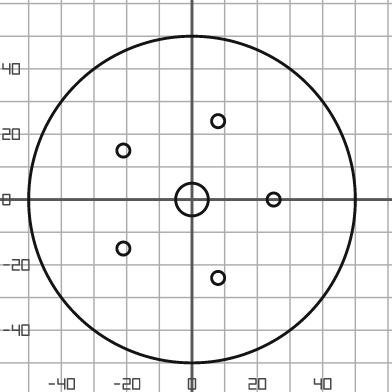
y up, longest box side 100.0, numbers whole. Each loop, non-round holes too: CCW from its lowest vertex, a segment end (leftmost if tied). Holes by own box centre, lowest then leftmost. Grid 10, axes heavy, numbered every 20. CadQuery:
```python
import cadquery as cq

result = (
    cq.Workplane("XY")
    .moveTo(0.0, 0.0)
    .circle(50.0)
    .moveTo(8.0, -24.0)
    .circle(2.0)
    .moveTo(-21.0, -15.0)
    .circle(2.0)
    .moveTo(0.0, 0.0)
    .circle(5.0)
    .moveTo(25.0, 0.0)
    .circle(2.0)
    .moveTo(-21.0, 15.0)
    .circle(2.0)
    .moveTo(8.0, 24.0)
    .circle(2.0)
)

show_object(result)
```